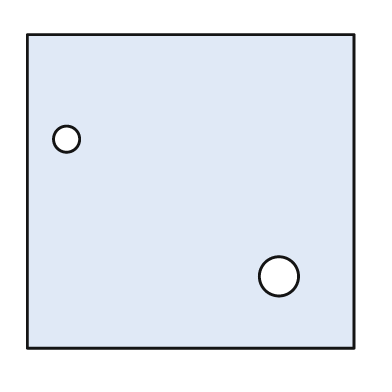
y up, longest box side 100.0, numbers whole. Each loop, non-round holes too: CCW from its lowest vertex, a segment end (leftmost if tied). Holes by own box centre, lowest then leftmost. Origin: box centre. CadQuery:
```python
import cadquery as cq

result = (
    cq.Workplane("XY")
    .moveTo(-50.0, -48.0)
    .lineTo(50.0, -48.0)
    .lineTo(50.0, 48.0)
    .lineTo(-50.0, 48.0)
    .close()
    .moveTo(27.0, -26.0)
    .circle(6.0)
    .moveTo(-38.0, 16.0)
    .circle(4.0)
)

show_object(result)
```